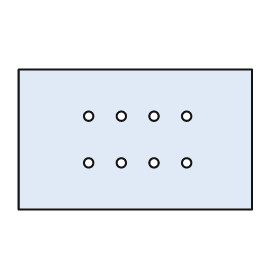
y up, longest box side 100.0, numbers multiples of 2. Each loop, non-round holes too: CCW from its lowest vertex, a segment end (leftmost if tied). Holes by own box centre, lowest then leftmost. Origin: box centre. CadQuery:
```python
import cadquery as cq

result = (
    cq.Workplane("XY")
    .moveTo(-50.0, -30.0)
    .lineTo(50.0, -30.0)
    .lineTo(50.0, 30.0)
    .lineTo(-50.0, 30.0)
    .close()
    .moveTo(-20.0, -10.0)
    .circle(2.0)
    .moveTo(-6.0, -10.0)
    .circle(2.0)
    .moveTo(8.0, -10.0)
    .circle(2.0)
    .moveTo(22.0, -10.0)
    .circle(2.0)
    .moveTo(-20.0, 10.0)
    .circle(2.0)
    .moveTo(-6.0, 10.0)
    .circle(2.0)
    .moveTo(8.0, 10.0)
    .circle(2.0)
    .moveTo(22.0, 10.0)
    .circle(2.0)
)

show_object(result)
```